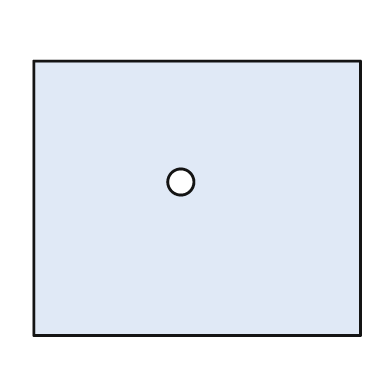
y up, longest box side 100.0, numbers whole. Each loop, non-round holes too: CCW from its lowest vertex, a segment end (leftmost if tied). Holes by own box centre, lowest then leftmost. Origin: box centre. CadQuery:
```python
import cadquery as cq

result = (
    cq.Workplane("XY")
    .moveTo(-50.0, -42.0)
    .lineTo(50.0, -42.0)
    .lineTo(50.0, 42.0)
    .lineTo(-50.0, 42.0)
    .close()
    .moveTo(-5.0, 5.0)
    .circle(4.0)
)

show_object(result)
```